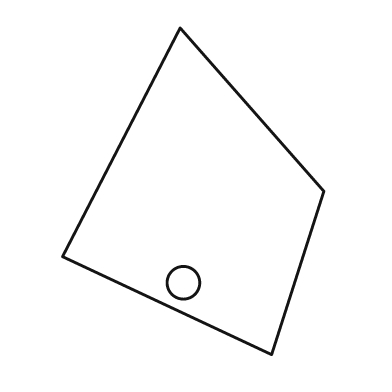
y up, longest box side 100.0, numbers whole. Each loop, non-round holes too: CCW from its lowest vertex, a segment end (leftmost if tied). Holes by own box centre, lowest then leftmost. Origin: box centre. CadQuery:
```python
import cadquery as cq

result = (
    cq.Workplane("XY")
    .moveTo(24.0, -50.0)
    .lineTo(40.0, 0.0)
    .lineTo(-4.0, 50.0)
    .lineTo(-40.0, -20.0)
    .close()
    .moveTo(-3.0, -28.0)
    .circle(5.0)
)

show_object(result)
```